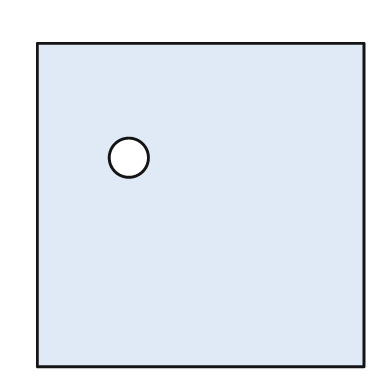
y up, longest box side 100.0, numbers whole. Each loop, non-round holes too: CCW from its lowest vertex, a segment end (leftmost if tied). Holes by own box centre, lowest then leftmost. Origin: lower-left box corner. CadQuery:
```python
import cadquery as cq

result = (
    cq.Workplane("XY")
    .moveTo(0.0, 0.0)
    .lineTo(100.0, 0.0)
    .lineTo(100.0, 99.0)
    .lineTo(0.0, 99.0)
    .close()
    .moveTo(28.0, 64.0)
    .circle(6.0)
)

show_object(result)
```